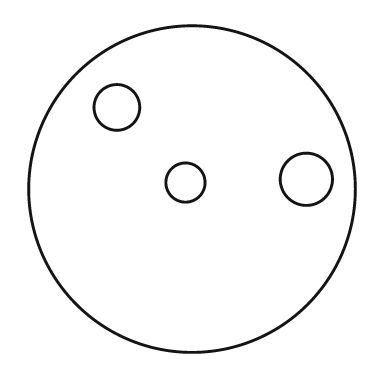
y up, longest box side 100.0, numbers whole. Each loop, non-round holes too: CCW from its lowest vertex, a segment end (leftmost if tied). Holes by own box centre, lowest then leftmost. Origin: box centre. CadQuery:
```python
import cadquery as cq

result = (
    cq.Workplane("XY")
    .moveTo(0.0, 0.0)
    .circle(50.0)
    .moveTo(-2.0, 2.0)
    .circle(6.0)
    .moveTo(35.0, 3.0)
    .circle(8.0)
    .moveTo(-23.0, 25.0)
    .circle(7.0)
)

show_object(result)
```